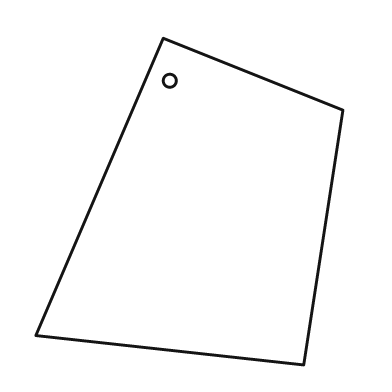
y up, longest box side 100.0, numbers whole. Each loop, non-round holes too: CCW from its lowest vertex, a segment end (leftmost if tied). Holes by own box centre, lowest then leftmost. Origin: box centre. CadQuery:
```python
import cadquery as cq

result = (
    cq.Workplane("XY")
    .moveTo(35.0, -50.0)
    .lineTo(47.0, 28.0)
    .lineTo(-8.0, 50.0)
    .lineTo(-47.0, -41.0)
    .close()
    .moveTo(-6.0, 37.0)
    .circle(2.0)
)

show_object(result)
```